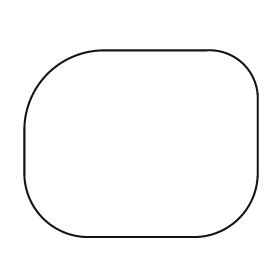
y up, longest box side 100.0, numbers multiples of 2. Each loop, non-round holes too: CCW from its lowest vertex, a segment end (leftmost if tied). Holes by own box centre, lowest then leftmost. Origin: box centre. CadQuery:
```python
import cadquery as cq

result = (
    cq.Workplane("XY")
    .moveTo(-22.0, -40.0)
    .lineTo(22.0, -40.0)
    .threePointArc((42.0, -32.0), (50.0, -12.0))
    .lineTo(50.0, 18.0)
    .threePointArc((44.0, 34.0), (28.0, 40.0))
    .lineTo(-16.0, 40.0)
    .threePointArc((-40.0, 30.0), (-50.0, 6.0))
    .lineTo(-50.0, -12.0)
    .threePointArc((-42.0, -32.0), (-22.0, -40.0))
    .close()
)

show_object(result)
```